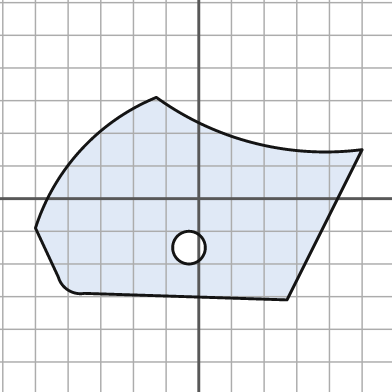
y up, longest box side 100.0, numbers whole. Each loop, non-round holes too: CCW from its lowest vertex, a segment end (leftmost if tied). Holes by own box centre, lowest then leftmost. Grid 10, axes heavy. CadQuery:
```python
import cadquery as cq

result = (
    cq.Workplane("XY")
    .moveTo(27.0, -31.0)
    .lineTo(50.0, 15.0)
    .threePointArc((17.0, 17.0), (-13.0, 31.0))
    .threePointArc((-36.0, 15.0), (-50.0, -9.0))
    .lineTo(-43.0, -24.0)
    .threePointArc((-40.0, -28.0), (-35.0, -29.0))
    .close()
    .moveTo(-3.0, -15.0)
    .circle(5.0)
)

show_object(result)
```